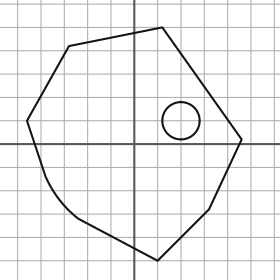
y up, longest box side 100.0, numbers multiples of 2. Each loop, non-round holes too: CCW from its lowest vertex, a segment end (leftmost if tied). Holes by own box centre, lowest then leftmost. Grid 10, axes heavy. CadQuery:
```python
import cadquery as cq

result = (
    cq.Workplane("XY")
    .moveTo(10.0, -50.0)
    .lineTo(32.0, -28.0)
    .lineTo(46.0, 2.0)
    .lineTo(12.0, 50.0)
    .lineTo(-28.0, 42.0)
    .lineTo(-46.0, 10.0)
    .lineTo(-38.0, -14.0)
    .threePointArc((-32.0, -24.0), (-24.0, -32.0))
    .close()
    .moveTo(20.0, 10.0)
    .circle(8.0)
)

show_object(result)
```